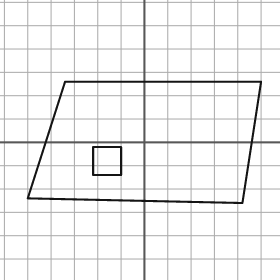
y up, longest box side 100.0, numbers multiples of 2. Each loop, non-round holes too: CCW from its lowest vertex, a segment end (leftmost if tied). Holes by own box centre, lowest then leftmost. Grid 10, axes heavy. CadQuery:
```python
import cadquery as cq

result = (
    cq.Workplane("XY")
    .moveTo(42.0, -26.0)
    .lineTo(50.0, 26.0)
    .lineTo(-34.0, 26.0)
    .lineTo(-50.0, -24.0)
    .close()
    .moveTo(-22.0, -14.0)
    .lineTo(-10.0, -14.0)
    .lineTo(-10.0, -2.0)
    .lineTo(-22.0, -2.0)
    .close()
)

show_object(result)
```